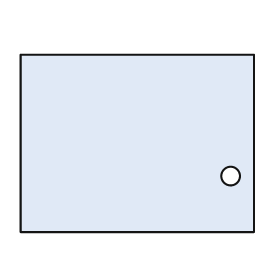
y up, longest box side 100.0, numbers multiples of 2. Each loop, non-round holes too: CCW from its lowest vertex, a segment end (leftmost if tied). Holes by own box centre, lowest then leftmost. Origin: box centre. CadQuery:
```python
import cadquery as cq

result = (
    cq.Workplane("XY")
    .moveTo(-50.0, -38.0)
    .lineTo(50.0, -38.0)
    .lineTo(50.0, 38.0)
    .lineTo(-50.0, 38.0)
    .close()
    .moveTo(40.0, -14.0)
    .circle(4.0)
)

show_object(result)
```